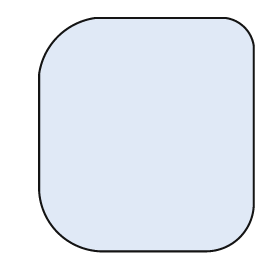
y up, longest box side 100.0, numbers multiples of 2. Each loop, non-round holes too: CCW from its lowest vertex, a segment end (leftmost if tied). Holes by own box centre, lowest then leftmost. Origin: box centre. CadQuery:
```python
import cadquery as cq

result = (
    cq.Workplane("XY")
    .moveTo(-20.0, -50.0)
    .lineTo(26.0, -50.0)
    .threePointArc((40.0, -44.0), (46.0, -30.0))
    .lineTo(46.0, 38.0)
    .threePointArc((42.0, 46.0), (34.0, 50.0))
    .lineTo(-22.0, 50.0)
    .threePointArc((-38.0, 42.0), (-46.0, 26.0))
    .lineTo(-46.0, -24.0)
    .threePointArc((-38.0, -42.0), (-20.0, -50.0))
    .close()
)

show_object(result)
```